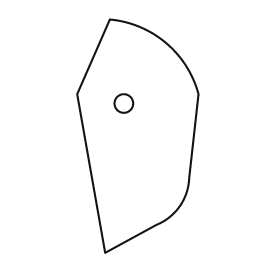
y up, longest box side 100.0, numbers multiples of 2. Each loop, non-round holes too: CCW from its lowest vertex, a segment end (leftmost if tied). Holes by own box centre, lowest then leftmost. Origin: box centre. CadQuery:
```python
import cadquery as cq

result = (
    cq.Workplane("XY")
    .moveTo(-14.0, -50.0)
    .lineTo(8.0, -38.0)
    .threePointArc((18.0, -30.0), (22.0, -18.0))
    .lineTo(26.0, 18.0)
    .threePointArc((12.0, 40.0), (-12.0, 50.0))
    .lineTo(-26.0, 18.0)
    .close()
    .moveTo(-6.0, 14.0)
    .circle(4.0)
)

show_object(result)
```